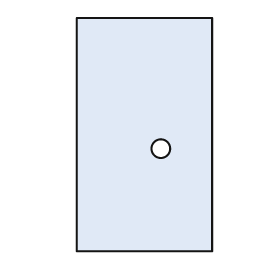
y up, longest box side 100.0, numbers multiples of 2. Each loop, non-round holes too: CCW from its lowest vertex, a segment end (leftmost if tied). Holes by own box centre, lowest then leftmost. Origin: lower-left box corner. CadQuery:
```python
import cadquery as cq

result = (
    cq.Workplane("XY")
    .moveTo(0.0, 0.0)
    .lineTo(58.0, 0.0)
    .lineTo(58.0, 100.0)
    .lineTo(0.0, 100.0)
    .close()
    .moveTo(36.0, 44.0)
    .circle(4.0)
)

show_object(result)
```